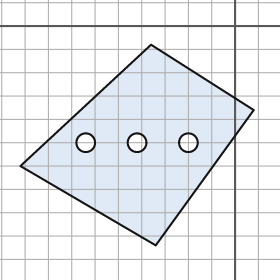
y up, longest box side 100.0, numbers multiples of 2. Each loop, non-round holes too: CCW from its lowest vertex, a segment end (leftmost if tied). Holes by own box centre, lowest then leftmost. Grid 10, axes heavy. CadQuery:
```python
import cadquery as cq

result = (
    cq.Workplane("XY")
    .moveTo(-34.0, -94.0)
    .lineTo(8.0, -36.0)
    .lineTo(-36.0, -8.0)
    .lineTo(-92.0, -60.0)
    .close()
    .moveTo(-64.0, -50.0)
    .circle(4.0)
    .moveTo(-42.0, -50.0)
    .circle(4.0)
    .moveTo(-20.0, -50.0)
    .circle(4.0)
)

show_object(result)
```